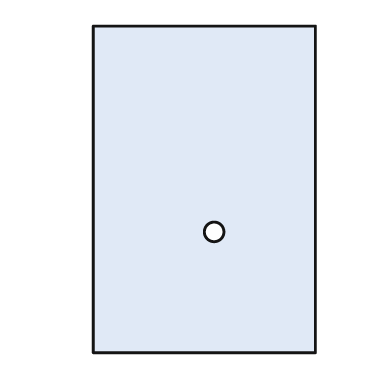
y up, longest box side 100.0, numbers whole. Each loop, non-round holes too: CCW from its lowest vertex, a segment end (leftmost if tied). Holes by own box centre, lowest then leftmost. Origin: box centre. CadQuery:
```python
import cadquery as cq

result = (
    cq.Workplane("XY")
    .moveTo(-34.0, -50.0)
    .lineTo(34.0, -50.0)
    .lineTo(34.0, 50.0)
    .lineTo(-34.0, 50.0)
    .close()
    .moveTo(3.0, -13.0)
    .circle(3.0)
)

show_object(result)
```